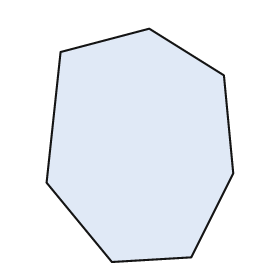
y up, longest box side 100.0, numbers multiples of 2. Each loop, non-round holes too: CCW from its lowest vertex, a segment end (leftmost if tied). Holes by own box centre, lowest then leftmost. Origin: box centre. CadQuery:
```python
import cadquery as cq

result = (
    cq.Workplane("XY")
    .moveTo(-12.0, -50.0)
    .lineTo(22.0, -48.0)
    .lineTo(40.0, -12.0)
    .lineTo(36.0, 30.0)
    .lineTo(4.0, 50.0)
    .lineTo(-34.0, 40.0)
    .lineTo(-40.0, -16.0)
    .close()
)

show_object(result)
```